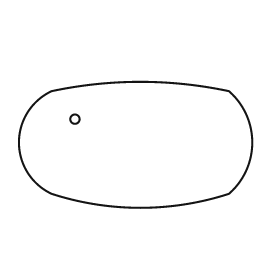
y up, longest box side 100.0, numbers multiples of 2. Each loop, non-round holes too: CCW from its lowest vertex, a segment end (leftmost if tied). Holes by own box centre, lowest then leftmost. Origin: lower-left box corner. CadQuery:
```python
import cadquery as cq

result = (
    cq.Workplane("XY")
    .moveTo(14.0, 6.0)
    .threePointArc((52.0, 0.0), (90.0, 6.0))
    .threePointArc((100.0, 28.0), (90.0, 50.0))
    .threePointArc((52.0, 54.0), (14.0, 50.0))
    .threePointArc((0.0, 28.0), (14.0, 6.0))
    .close()
    .moveTo(24.0, 38.0)
    .circle(2.0)
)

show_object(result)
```